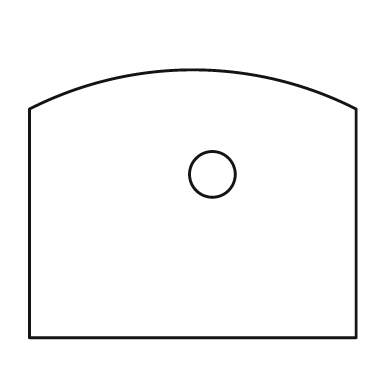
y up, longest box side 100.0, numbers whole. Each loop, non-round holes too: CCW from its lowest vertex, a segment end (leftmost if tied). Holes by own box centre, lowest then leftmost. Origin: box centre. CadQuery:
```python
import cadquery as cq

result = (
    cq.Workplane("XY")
    .moveTo(-50.0, -41.0)
    .lineTo(50.0, -41.0)
    .lineTo(50.0, 29.0)
    .threePointArc((0.0, 41.0), (-50.0, 29.0))
    .close()
    .moveTo(6.0, 9.0)
    .circle(7.0)
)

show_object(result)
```